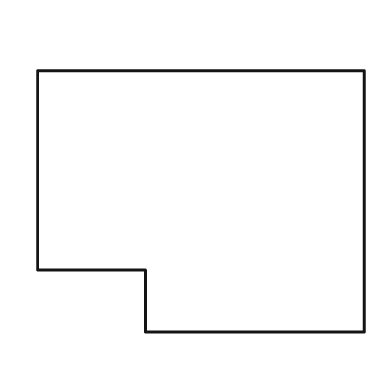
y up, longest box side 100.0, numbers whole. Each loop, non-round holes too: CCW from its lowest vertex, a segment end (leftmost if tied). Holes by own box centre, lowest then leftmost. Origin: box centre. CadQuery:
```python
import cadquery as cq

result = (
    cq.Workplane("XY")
    .moveTo(-17.0, -40.0)
    .lineTo(50.0, -40.0)
    .lineTo(50.0, 40.0)
    .lineTo(-50.0, 40.0)
    .lineTo(-50.0, -21.0)
    .lineTo(-17.0, -21.0)
    .close()
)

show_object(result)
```